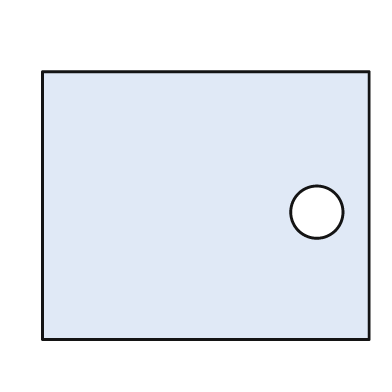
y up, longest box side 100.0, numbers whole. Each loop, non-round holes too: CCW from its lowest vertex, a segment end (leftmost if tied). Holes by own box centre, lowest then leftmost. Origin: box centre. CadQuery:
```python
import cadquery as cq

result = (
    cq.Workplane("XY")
    .moveTo(-50.0, -41.0)
    .lineTo(50.0, -41.0)
    .lineTo(50.0, 41.0)
    .lineTo(-50.0, 41.0)
    .close()
    .moveTo(34.0, -2.0)
    .circle(8.0)
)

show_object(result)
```